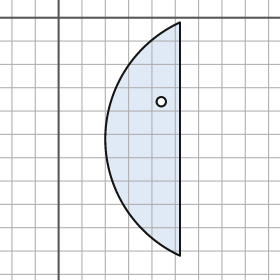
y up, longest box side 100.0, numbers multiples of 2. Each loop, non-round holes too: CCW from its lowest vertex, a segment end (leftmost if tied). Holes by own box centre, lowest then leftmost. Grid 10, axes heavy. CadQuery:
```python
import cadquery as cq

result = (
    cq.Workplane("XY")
    .moveTo(52.0, -102.0)
    .lineTo(52.0, -2.0)
    .threePointArc((20.0, -52.0), (52.0, -102.0))
    .close()
    .moveTo(44.0, -36.0)
    .circle(2.0)
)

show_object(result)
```